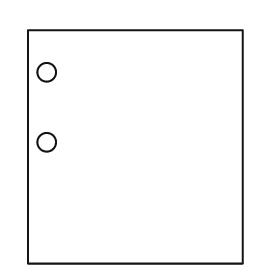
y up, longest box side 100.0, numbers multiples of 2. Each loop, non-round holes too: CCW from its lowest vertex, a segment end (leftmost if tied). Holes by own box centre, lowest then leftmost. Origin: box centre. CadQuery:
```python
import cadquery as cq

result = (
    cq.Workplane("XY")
    .moveTo(-46.0, -50.0)
    .lineTo(46.0, -50.0)
    .lineTo(46.0, 50.0)
    .lineTo(-46.0, 50.0)
    .close()
    .moveTo(-38.0, 2.0)
    .circle(4.0)
    .moveTo(-38.0, 32.0)
    .circle(4.0)
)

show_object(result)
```